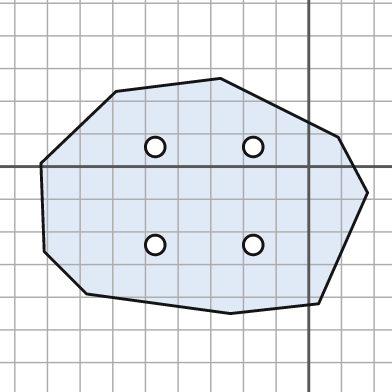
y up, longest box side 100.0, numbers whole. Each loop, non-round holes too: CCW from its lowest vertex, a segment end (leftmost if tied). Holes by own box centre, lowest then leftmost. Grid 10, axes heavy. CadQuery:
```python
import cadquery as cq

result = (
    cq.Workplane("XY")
    .moveTo(-24.0, -45.0)
    .lineTo(3.0, -42.0)
    .lineTo(18.0, -8.0)
    .lineTo(9.0, 9.0)
    .lineTo(-27.0, 27.0)
    .lineTo(-59.0, 23.0)
    .lineTo(-82.0, 1.0)
    .lineTo(-81.0, -26.0)
    .lineTo(-68.0, -39.0)
    .close()
    .moveTo(-47.0, -24.0)
    .circle(3.0)
    .moveTo(-17.0, -24.0)
    .circle(3.0)
    .moveTo(-47.0, 6.0)
    .circle(3.0)
    .moveTo(-17.0, 6.0)
    .circle(3.0)
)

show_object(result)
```